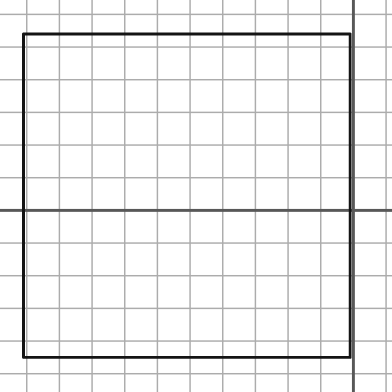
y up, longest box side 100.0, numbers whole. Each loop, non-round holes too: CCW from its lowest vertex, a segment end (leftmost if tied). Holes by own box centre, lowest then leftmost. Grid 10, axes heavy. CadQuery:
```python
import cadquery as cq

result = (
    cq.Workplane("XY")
    .moveTo(-101.0, -45.0)
    .lineTo(-1.0, -45.0)
    .lineTo(-1.0, 54.0)
    .lineTo(-101.0, 54.0)
    .close()
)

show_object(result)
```